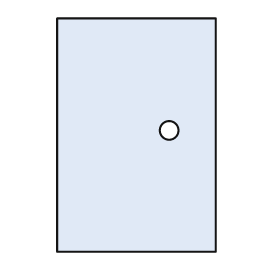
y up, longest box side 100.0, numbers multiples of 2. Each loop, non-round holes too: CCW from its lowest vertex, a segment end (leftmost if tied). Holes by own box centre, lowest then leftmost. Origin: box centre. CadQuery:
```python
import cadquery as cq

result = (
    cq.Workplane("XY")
    .moveTo(-34.0, -50.0)
    .lineTo(34.0, -50.0)
    .lineTo(34.0, 50.0)
    .lineTo(-34.0, 50.0)
    .close()
    .moveTo(14.0, 2.0)
    .circle(4.0)
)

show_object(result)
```